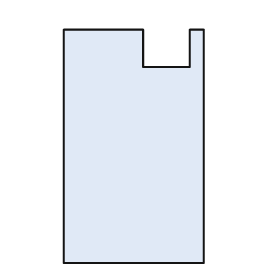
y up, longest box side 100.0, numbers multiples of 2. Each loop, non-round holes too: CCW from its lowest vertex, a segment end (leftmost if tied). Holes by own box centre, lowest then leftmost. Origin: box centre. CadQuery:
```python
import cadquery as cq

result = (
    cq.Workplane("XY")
    .moveTo(-30.0, -50.0)
    .lineTo(30.0, -50.0)
    .lineTo(30.0, 50.0)
    .lineTo(24.0, 50.0)
    .lineTo(24.0, 34.0)
    .lineTo(4.0, 34.0)
    .lineTo(4.0, 50.0)
    .lineTo(-30.0, 50.0)
    .close()
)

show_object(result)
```